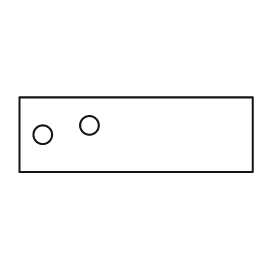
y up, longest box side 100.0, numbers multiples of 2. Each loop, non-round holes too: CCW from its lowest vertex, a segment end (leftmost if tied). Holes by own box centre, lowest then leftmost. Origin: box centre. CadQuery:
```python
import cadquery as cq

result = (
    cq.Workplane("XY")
    .moveTo(-50.0, -16.0)
    .lineTo(50.0, -16.0)
    .lineTo(50.0, 16.0)
    .lineTo(-50.0, 16.0)
    .close()
    .moveTo(-40.0, 0.0)
    .circle(4.0)
    .moveTo(-20.0, 4.0)
    .circle(4.0)
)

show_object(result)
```